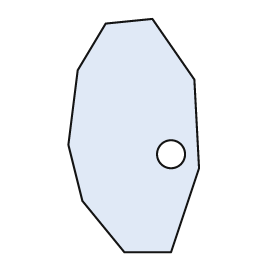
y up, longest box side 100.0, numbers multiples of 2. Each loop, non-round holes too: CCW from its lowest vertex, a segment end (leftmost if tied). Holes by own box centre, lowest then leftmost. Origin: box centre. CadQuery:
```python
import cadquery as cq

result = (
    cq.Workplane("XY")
    .moveTo(-4.0, -50.0)
    .lineTo(16.0, -50.0)
    .lineTo(28.0, -14.0)
    .lineTo(26.0, 24.0)
    .lineTo(8.0, 50.0)
    .lineTo(-12.0, 48.0)
    .lineTo(-24.0, 28.0)
    .lineTo(-28.0, -4.0)
    .lineTo(-22.0, -28.0)
    .close()
    .moveTo(16.0, -8.0)
    .circle(6.0)
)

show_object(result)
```